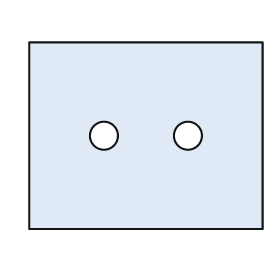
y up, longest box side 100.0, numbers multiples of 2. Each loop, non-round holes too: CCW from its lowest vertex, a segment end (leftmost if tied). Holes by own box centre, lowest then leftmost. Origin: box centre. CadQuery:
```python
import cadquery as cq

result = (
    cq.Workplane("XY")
    .moveTo(-50.0, -40.0)
    .lineTo(50.0, -40.0)
    .lineTo(50.0, 40.0)
    .lineTo(-50.0, 40.0)
    .close()
    .moveTo(-18.0, 0.0)
    .circle(6.0)
    .moveTo(18.0, 0.0)
    .circle(6.0)
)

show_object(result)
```